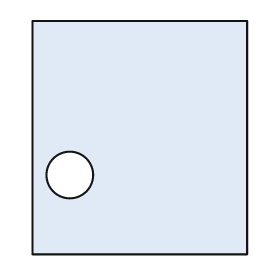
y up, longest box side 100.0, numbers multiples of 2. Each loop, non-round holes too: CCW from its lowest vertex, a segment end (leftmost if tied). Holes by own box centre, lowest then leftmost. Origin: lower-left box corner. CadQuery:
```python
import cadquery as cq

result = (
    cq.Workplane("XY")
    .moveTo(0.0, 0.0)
    .lineTo(92.0, 0.0)
    .lineTo(92.0, 100.0)
    .lineTo(0.0, 100.0)
    .close()
    .moveTo(16.0, 34.0)
    .circle(10.0)
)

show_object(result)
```